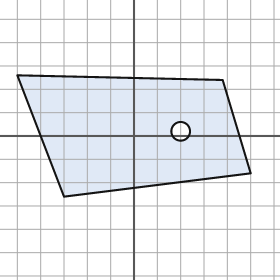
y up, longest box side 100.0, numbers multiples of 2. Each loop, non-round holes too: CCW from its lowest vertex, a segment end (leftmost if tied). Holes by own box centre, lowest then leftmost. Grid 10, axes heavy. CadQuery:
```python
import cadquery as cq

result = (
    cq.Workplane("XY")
    .moveTo(-30.0, -26.0)
    .lineTo(50.0, -16.0)
    .lineTo(38.0, 24.0)
    .lineTo(-50.0, 26.0)
    .close()
    .moveTo(20.0, 2.0)
    .circle(4.0)
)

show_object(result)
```